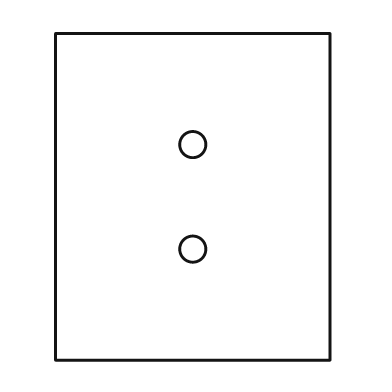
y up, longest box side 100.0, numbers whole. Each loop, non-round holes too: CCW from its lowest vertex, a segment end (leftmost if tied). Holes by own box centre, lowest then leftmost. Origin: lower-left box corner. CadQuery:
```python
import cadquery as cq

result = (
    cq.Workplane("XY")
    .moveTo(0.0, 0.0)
    .lineTo(84.0, 0.0)
    .lineTo(84.0, 100.0)
    .lineTo(0.0, 100.0)
    .close()
    .moveTo(42.0, 34.0)
    .circle(4.0)
    .moveTo(42.0, 66.0)
    .circle(4.0)
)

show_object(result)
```